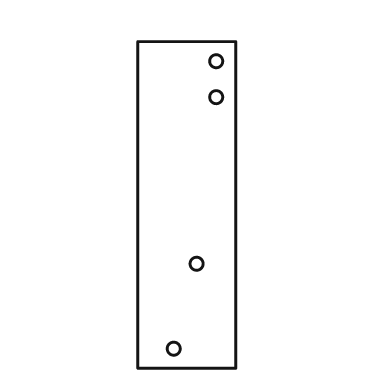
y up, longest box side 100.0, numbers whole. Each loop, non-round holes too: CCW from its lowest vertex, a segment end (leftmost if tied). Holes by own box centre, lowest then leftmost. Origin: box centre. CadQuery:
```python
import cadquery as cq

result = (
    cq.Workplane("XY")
    .moveTo(-15.0, -50.0)
    .lineTo(15.0, -50.0)
    .lineTo(15.0, 50.0)
    .lineTo(-15.0, 50.0)
    .close()
    .moveTo(-4.0, -44.0)
    .circle(2.0)
    .moveTo(3.0, -18.0)
    .circle(2.0)
    .moveTo(9.0, 33.0)
    .circle(2.0)
    .moveTo(9.0, 44.0)
    .circle(2.0)
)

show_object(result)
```